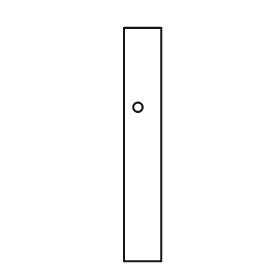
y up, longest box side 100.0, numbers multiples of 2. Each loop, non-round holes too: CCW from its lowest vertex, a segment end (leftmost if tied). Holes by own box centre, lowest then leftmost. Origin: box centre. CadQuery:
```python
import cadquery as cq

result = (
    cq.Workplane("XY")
    .moveTo(-8.0, -50.0)
    .lineTo(8.0, -50.0)
    .lineTo(8.0, 50.0)
    .lineTo(-8.0, 50.0)
    .close()
    .moveTo(-2.0, 16.0)
    .circle(2.0)
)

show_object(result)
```